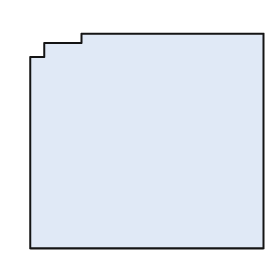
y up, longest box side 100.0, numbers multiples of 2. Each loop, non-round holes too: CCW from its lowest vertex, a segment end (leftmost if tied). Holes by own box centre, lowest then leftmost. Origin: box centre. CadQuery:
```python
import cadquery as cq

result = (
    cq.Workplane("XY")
    .moveTo(-50.0, -46.0)
    .lineTo(50.0, -46.0)
    .lineTo(50.0, 46.0)
    .lineTo(-28.0, 46.0)
    .lineTo(-28.0, 42.0)
    .lineTo(-44.0, 42.0)
    .lineTo(-44.0, 36.0)
    .lineTo(-50.0, 36.0)
    .close()
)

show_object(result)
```